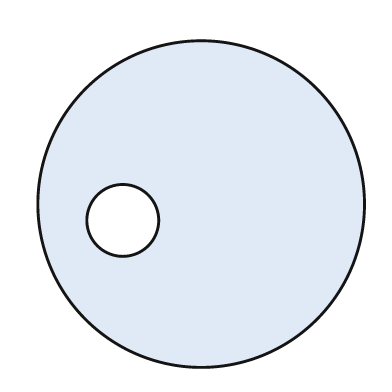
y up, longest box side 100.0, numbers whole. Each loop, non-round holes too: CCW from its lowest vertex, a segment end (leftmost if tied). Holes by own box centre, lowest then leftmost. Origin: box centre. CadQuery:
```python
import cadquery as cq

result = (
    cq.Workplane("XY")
    .moveTo(0.0, 0.0)
    .circle(50.0)
    .moveTo(-24.0, -5.0)
    .circle(11.0)
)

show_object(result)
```